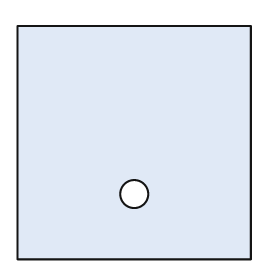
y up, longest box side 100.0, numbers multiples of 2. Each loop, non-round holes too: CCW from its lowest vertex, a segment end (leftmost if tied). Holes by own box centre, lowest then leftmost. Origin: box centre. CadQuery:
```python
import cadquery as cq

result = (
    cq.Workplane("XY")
    .moveTo(-50.0, -50.0)
    .lineTo(50.0, -50.0)
    .lineTo(50.0, 50.0)
    .lineTo(-50.0, 50.0)
    .close()
    .moveTo(0.0, -22.0)
    .circle(6.0)
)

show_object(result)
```